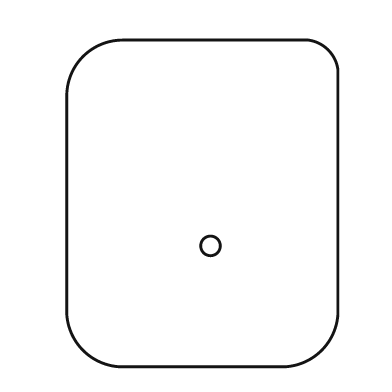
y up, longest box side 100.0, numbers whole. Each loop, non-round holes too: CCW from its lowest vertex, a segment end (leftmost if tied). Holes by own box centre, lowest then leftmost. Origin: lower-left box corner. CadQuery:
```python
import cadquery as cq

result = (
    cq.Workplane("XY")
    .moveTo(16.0, 0.0)
    .lineTo(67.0, 0.0)
    .threePointArc((78.0, 5.0), (83.0, 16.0))
    .lineTo(83.0, 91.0)
    .threePointArc((80.0, 97.0), (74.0, 100.0))
    .lineTo(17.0, 100.0)
    .threePointArc((5.0, 95.0), (0.0, 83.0))
    .lineTo(0.0, 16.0)
    .threePointArc((5.0, 5.0), (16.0, 0.0))
    .close()
    .moveTo(44.0, 37.0)
    .circle(3.0)
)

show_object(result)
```